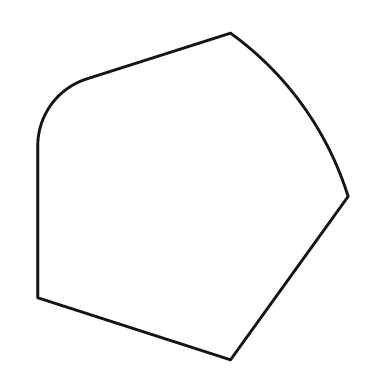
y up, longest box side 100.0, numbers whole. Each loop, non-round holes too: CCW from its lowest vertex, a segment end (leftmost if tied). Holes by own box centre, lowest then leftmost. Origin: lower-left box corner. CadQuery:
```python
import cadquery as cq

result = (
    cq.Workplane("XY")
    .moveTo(59.0, 0.0)
    .lineTo(95.0, 50.0)
    .threePointArc((81.0, 78.0), (59.0, 100.0))
    .lineTo(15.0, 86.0)
    .threePointArc((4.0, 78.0), (0.0, 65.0))
    .lineTo(0.0, 19.0)
    .close()
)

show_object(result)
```